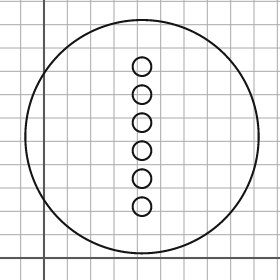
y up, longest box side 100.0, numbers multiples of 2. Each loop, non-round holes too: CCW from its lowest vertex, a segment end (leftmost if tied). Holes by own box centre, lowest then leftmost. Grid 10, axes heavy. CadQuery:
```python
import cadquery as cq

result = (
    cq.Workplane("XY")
    .moveTo(42.0, 52.0)
    .circle(50.0)
    .moveTo(42.0, 22.0)
    .circle(4.0)
    .moveTo(42.0, 34.0)
    .circle(4.0)
    .moveTo(42.0, 46.0)
    .circle(4.0)
    .moveTo(42.0, 58.0)
    .circle(4.0)
    .moveTo(42.0, 70.0)
    .circle(4.0)
    .moveTo(42.0, 82.0)
    .circle(4.0)
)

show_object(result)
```